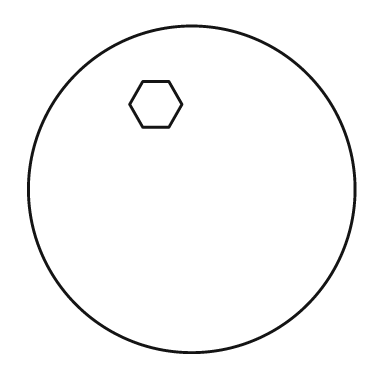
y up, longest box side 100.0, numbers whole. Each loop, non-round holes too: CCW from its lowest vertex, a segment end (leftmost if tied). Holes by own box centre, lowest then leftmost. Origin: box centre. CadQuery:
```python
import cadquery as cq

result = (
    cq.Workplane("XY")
    .moveTo(0.0, 0.0)
    .circle(50.0)
    .moveTo(-15.0, 19.0)
    .lineTo(-7.0, 19.0)
    .lineTo(-3.0, 26.0)
    .lineTo(-7.0, 33.0)
    .lineTo(-15.0, 33.0)
    .lineTo(-19.0, 26.0)
    .close()
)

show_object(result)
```